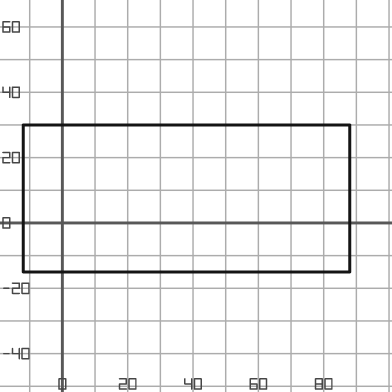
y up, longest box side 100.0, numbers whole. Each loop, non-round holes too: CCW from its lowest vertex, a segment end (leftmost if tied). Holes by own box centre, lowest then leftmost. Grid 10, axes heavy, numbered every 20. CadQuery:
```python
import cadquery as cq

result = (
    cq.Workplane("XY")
    .moveTo(-12.0, -15.0)
    .lineTo(88.0, -15.0)
    .lineTo(88.0, 30.0)
    .lineTo(-12.0, 30.0)
    .close()
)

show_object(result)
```